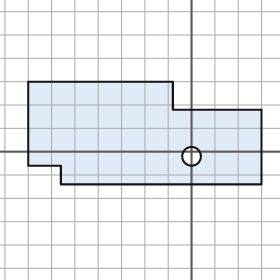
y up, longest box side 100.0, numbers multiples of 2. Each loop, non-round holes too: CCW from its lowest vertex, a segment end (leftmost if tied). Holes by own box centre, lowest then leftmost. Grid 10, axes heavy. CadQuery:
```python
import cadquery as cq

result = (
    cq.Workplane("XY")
    .moveTo(-56.0, -14.0)
    .lineTo(30.0, -14.0)
    .lineTo(30.0, 18.0)
    .lineTo(-8.0, 18.0)
    .lineTo(-8.0, 30.0)
    .lineTo(-70.0, 30.0)
    .lineTo(-70.0, -6.0)
    .lineTo(-56.0, -6.0)
    .close()
    .moveTo(0.0, -2.0)
    .circle(4.0)
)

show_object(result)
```